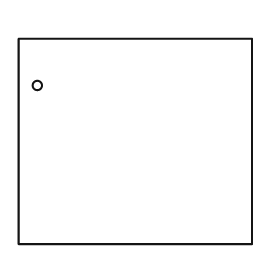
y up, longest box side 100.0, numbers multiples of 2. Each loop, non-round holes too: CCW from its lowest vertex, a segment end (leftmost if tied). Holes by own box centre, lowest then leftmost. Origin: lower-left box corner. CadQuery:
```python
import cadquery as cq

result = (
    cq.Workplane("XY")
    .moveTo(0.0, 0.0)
    .lineTo(100.0, 0.0)
    .lineTo(100.0, 88.0)
    .lineTo(0.0, 88.0)
    .close()
    .moveTo(8.0, 68.0)
    .circle(2.0)
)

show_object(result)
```